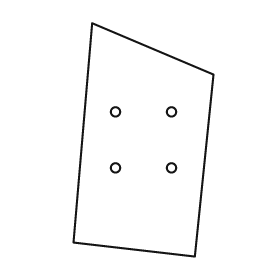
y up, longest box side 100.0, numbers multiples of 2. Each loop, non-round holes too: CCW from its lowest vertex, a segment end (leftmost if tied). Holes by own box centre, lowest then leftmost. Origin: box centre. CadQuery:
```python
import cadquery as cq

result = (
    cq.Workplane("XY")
    .moveTo(22.0, -50.0)
    .lineTo(30.0, 28.0)
    .lineTo(-22.0, 50.0)
    .lineTo(-30.0, -44.0)
    .close()
    .moveTo(-12.0, -12.0)
    .circle(2.0)
    .moveTo(12.0, -12.0)
    .circle(2.0)
    .moveTo(-12.0, 12.0)
    .circle(2.0)
    .moveTo(12.0, 12.0)
    .circle(2.0)
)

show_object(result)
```